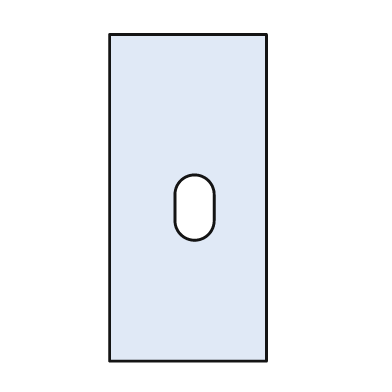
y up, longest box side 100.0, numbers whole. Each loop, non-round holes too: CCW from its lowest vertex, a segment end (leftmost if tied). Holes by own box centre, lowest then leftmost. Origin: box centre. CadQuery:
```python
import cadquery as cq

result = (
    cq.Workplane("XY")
    .moveTo(-24.0, -50.0)
    .lineTo(24.0, -50.0)
    .lineTo(24.0, 50.0)
    .lineTo(-24.0, 50.0)
    .close()
    .moveTo(-4.0, -7.0)
    .threePointArc((2.0, -13.0), (8.0, -7.0))
    .lineTo(8.0, 1.0)
    .threePointArc((2.0, 7.0), (-4.0, 1.0))
    .close()
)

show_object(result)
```